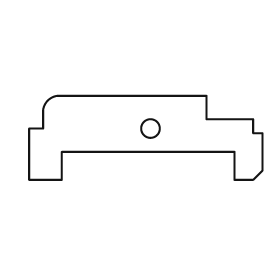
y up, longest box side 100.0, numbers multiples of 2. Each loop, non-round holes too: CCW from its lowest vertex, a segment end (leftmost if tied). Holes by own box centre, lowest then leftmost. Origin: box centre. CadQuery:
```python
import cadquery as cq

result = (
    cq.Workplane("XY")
    .moveTo(-50.0, -18.0)
    .lineTo(-36.0, -18.0)
    .lineTo(-36.0, -6.0)
    .lineTo(38.0, -6.0)
    .lineTo(38.0, -18.0)
    .lineTo(46.0, -18.0)
    .lineTo(50.0, -14.0)
    .lineTo(50.0, 2.0)
    .lineTo(46.0, 2.0)
    .lineTo(46.0, 8.0)
    .lineTo(26.0, 8.0)
    .lineTo(26.0, 18.0)
    .lineTo(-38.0, 18.0)
    .threePointArc((-42.0, 16.0), (-44.0, 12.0))
    .lineTo(-44.0, 4.0)
    .lineTo(-50.0, 4.0)
    .close()
    .moveTo(2.0, 4.0)
    .circle(4.0)
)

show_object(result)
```